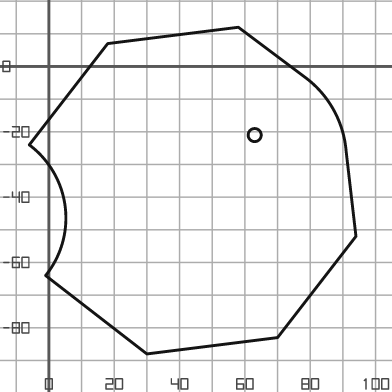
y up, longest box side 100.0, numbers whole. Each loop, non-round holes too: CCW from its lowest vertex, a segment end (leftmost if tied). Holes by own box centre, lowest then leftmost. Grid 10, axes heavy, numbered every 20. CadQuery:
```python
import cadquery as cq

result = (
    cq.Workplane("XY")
    .moveTo(30.0, -88.0)
    .lineTo(70.0, -83.0)
    .lineTo(94.0, -52.0)
    .lineTo(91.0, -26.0)
    .threePointArc((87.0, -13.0), (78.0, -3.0))
    .lineTo(58.0, 12.0)
    .lineTo(18.0, 7.0)
    .lineTo(-6.0, -24.0)
    .threePointArc((5.0, -43.0), (-1.0, -64.0))
    .close()
    .moveTo(63.0, -21.0)
    .circle(2.0)
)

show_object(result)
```